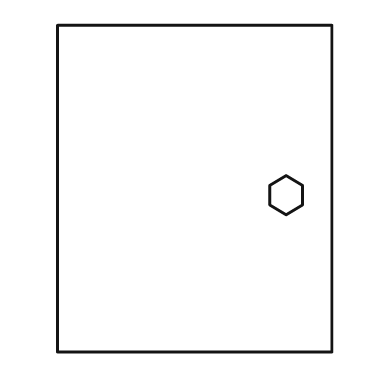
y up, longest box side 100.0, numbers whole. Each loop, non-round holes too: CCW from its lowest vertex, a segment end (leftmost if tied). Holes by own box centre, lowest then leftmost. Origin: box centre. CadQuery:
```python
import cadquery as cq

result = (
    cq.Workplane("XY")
    .moveTo(-42.0, -50.0)
    .lineTo(42.0, -50.0)
    .lineTo(42.0, 50.0)
    .lineTo(-42.0, 50.0)
    .close()
    .moveTo(28.0, -8.0)
    .lineTo(33.0, -5.0)
    .lineTo(33.0, 1.0)
    .lineTo(28.0, 4.0)
    .lineTo(23.0, 1.0)
    .lineTo(23.0, -5.0)
    .close()
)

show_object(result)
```